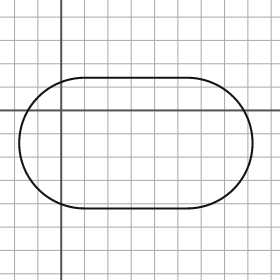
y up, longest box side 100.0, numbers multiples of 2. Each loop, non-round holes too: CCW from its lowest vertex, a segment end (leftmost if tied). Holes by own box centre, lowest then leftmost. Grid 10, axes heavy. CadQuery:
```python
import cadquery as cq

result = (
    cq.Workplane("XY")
    .moveTo(10.0, -42.0)
    .lineTo(54.0, -42.0)
    .threePointArc((82.0, -14.0), (54.0, 14.0))
    .lineTo(10.0, 14.0)
    .threePointArc((-18.0, -14.0), (10.0, -42.0))
    .close()
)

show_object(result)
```